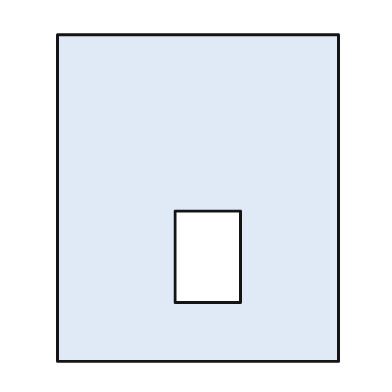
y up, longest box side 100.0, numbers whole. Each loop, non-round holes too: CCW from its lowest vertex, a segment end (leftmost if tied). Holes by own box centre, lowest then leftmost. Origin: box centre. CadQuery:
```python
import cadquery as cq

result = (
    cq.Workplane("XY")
    .moveTo(-43.0, -50.0)
    .lineTo(43.0, -50.0)
    .lineTo(43.0, 50.0)
    .lineTo(-43.0, 50.0)
    .close()
    .moveTo(-7.0, -32.0)
    .lineTo(13.0, -32.0)
    .lineTo(13.0, -4.0)
    .lineTo(-7.0, -4.0)
    .close()
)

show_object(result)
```